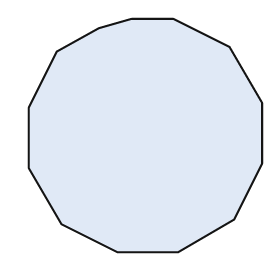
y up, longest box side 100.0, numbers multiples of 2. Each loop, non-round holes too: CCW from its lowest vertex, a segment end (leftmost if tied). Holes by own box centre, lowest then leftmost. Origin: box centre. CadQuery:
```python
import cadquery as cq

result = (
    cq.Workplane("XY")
    .moveTo(-12.0, -50.0)
    .lineTo(14.0, -50.0)
    .lineTo(38.0, -36.0)
    .lineTo(50.0, -12.0)
    .lineTo(50.0, 14.0)
    .lineTo(36.0, 38.0)
    .lineTo(12.0, 50.0)
    .lineTo(-6.0, 50.0)
    .lineTo(-20.0, 46.0)
    .lineTo(-38.0, 36.0)
    .lineTo(-50.0, 12.0)
    .lineTo(-50.0, -14.0)
    .lineTo(-36.0, -38.0)
    .close()
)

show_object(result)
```